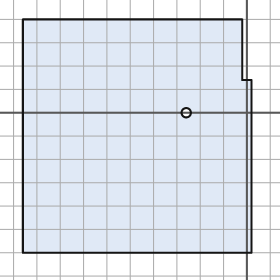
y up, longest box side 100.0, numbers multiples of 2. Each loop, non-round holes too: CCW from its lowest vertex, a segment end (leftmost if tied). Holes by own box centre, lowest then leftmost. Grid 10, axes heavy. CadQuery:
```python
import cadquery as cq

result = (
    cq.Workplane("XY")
    .moveTo(-96.0, -60.0)
    .lineTo(2.0, -60.0)
    .lineTo(2.0, 14.0)
    .lineTo(-2.0, 14.0)
    .lineTo(-2.0, 40.0)
    .lineTo(-96.0, 40.0)
    .close()
    .moveTo(-26.0, 0.0)
    .circle(2.0)
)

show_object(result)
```